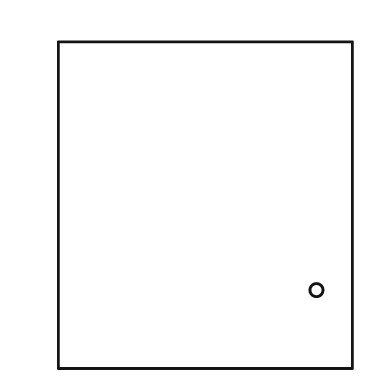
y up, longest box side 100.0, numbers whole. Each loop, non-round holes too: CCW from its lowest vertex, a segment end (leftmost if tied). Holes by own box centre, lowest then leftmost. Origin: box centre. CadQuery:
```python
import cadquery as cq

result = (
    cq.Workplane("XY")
    .moveTo(-45.0, -50.0)
    .lineTo(45.0, -50.0)
    .lineTo(45.0, 50.0)
    .lineTo(-45.0, 50.0)
    .close()
    .moveTo(34.0, -26.0)
    .circle(2.0)
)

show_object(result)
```